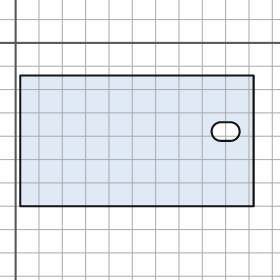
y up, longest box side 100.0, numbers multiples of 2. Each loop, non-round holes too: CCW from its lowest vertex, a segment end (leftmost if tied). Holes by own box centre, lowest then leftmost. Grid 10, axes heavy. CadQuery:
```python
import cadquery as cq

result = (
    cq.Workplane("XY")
    .moveTo(2.0, -70.0)
    .lineTo(102.0, -70.0)
    .lineTo(102.0, -14.0)
    .lineTo(2.0, -14.0)
    .close()
    .moveTo(88.0, -42.0)
    .lineTo(92.0, -42.0)
    .threePointArc((96.0, -38.0), (92.0, -34.0))
    .lineTo(88.0, -34.0)
    .threePointArc((84.0, -38.0), (88.0, -42.0))
    .close()
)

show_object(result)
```